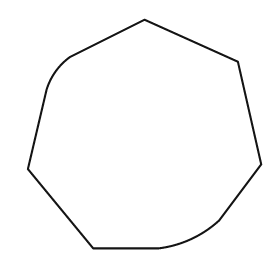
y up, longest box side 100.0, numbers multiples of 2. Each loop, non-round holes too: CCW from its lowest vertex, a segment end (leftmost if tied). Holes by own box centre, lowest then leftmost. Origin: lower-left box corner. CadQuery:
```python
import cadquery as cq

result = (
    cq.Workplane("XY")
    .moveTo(28.0, 0.0)
    .lineTo(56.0, 0.0)
    .threePointArc((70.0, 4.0), (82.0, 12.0))
    .lineTo(100.0, 36.0)
    .lineTo(90.0, 80.0)
    .lineTo(50.0, 98.0)
    .lineTo(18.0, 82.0)
    .threePointArc((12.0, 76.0), (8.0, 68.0))
    .lineTo(0.0, 34.0)
    .close()
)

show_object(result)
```